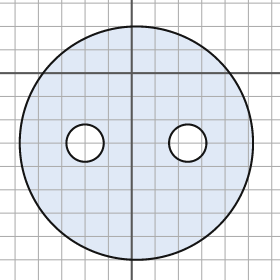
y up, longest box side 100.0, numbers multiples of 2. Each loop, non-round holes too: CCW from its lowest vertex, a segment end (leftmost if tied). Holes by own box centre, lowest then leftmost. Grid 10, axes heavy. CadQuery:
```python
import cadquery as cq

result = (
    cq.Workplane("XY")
    .moveTo(2.0, -30.0)
    .circle(50.0)
    .moveTo(-20.0, -30.0)
    .circle(8.0)
    .moveTo(24.0, -30.0)
    .circle(8.0)
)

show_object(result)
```